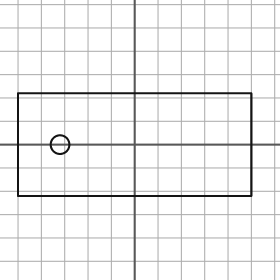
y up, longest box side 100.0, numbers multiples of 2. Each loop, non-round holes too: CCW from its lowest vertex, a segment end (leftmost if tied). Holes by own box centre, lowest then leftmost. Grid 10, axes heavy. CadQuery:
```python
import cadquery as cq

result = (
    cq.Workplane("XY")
    .moveTo(-50.0, -22.0)
    .lineTo(50.0, -22.0)
    .lineTo(50.0, 22.0)
    .lineTo(-50.0, 22.0)
    .close()
    .moveTo(-32.0, 0.0)
    .circle(4.0)
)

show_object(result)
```